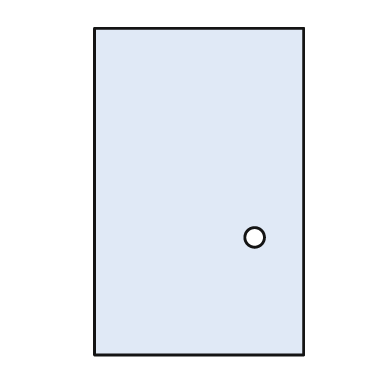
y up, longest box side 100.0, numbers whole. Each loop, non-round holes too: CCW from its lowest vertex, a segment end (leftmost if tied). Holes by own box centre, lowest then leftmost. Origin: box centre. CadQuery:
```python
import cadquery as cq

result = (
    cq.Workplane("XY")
    .moveTo(-32.0, -50.0)
    .lineTo(32.0, -50.0)
    .lineTo(32.0, 50.0)
    .lineTo(-32.0, 50.0)
    .close()
    .moveTo(17.0, -14.0)
    .circle(3.0)
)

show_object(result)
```